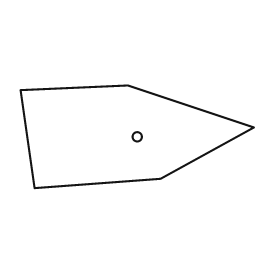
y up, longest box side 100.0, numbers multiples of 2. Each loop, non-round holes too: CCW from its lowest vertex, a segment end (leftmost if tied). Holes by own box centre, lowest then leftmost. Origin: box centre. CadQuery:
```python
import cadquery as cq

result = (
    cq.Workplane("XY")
    .moveTo(-44.0, -22.0)
    .lineTo(10.0, -18.0)
    .lineTo(50.0, 4.0)
    .lineTo(-4.0, 22.0)
    .lineTo(-50.0, 20.0)
    .close()
    .moveTo(0.0, 0.0)
    .circle(2.0)
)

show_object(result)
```